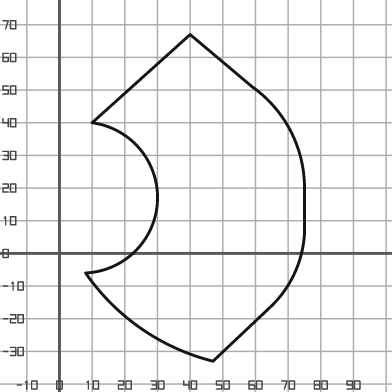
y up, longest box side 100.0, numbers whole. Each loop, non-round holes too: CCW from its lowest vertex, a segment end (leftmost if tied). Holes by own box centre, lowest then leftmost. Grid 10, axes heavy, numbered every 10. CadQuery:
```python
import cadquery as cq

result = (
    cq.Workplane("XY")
    .moveTo(47.0, -33.0)
    .lineTo(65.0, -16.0)
    .threePointArc((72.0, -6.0), (75.0, 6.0))
    .lineTo(75.0, 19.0)
    .threePointArc((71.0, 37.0), (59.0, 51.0))
    .lineTo(40.0, 67.0)
    .lineTo(10.0, 40.0)
    .threePointArc((30.0, 16.0), (8.0, -6.0))
    .threePointArc((25.0, -23.0), (47.0, -33.0))
    .close()
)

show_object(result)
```